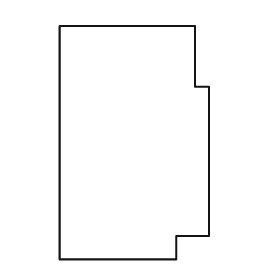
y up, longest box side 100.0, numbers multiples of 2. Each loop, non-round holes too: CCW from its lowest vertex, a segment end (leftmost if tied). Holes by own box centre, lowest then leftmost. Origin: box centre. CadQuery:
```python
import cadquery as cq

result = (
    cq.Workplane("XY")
    .moveTo(-32.0, -50.0)
    .lineTo(18.0, -50.0)
    .lineTo(18.0, -40.0)
    .lineTo(32.0, -40.0)
    .lineTo(32.0, 24.0)
    .lineTo(26.0, 24.0)
    .lineTo(26.0, 50.0)
    .lineTo(-32.0, 50.0)
    .close()
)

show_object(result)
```